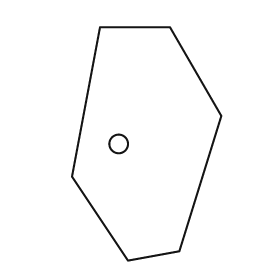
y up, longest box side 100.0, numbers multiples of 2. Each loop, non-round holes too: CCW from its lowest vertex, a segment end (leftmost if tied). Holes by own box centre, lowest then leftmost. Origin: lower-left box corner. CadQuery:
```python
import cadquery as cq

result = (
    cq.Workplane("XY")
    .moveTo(24.0, 0.0)
    .lineTo(46.0, 4.0)
    .lineTo(64.0, 62.0)
    .lineTo(42.0, 100.0)
    .lineTo(12.0, 100.0)
    .lineTo(0.0, 36.0)
    .close()
    .moveTo(20.0, 50.0)
    .circle(4.0)
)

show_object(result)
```